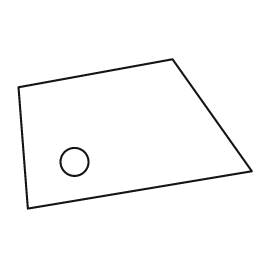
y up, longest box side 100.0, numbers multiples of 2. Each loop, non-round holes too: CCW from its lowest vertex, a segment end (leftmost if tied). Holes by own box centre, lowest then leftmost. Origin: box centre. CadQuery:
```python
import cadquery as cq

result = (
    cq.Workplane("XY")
    .moveTo(-46.0, -32.0)
    .lineTo(50.0, -16.0)
    .lineTo(16.0, 32.0)
    .lineTo(-50.0, 20.0)
    .close()
    .moveTo(-26.0, -12.0)
    .circle(6.0)
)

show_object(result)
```